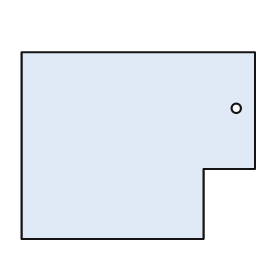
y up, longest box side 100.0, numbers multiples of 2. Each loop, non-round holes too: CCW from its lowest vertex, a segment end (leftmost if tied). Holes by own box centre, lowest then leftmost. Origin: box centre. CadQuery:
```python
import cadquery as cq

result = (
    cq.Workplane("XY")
    .moveTo(-50.0, -40.0)
    .lineTo(28.0, -40.0)
    .lineTo(28.0, -10.0)
    .lineTo(50.0, -10.0)
    .lineTo(50.0, 40.0)
    .lineTo(-50.0, 40.0)
    .close()
    .moveTo(42.0, 16.0)
    .circle(2.0)
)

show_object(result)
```